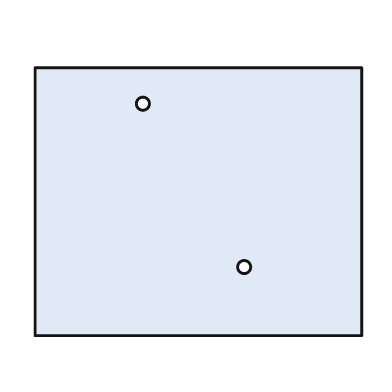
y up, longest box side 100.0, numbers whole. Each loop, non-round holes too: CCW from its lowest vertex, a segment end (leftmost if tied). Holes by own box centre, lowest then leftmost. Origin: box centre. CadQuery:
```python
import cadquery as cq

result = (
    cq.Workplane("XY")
    .moveTo(-50.0, -41.0)
    .lineTo(50.0, -41.0)
    .lineTo(50.0, 41.0)
    .lineTo(-50.0, 41.0)
    .close()
    .moveTo(14.0, -20.0)
    .circle(2.0)
    .moveTo(-17.0, 30.0)
    .circle(2.0)
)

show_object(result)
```